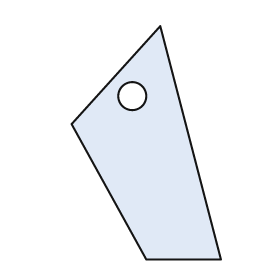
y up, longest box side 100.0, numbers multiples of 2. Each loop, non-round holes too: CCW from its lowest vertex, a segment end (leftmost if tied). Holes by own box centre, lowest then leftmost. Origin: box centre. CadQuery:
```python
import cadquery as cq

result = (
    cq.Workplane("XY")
    .moveTo(0.0, -50.0)
    .lineTo(32.0, -50.0)
    .lineTo(6.0, 50.0)
    .lineTo(-32.0, 8.0)
    .close()
    .moveTo(-6.0, 20.0)
    .circle(6.0)
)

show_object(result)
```